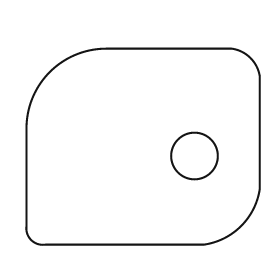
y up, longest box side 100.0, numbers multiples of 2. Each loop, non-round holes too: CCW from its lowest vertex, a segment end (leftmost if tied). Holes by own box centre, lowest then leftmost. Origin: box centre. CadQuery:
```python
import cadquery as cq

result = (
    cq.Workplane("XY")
    .moveTo(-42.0, -42.0)
    .lineTo(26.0, -42.0)
    .threePointArc((42.0, -34.0), (50.0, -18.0))
    .lineTo(50.0, 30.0)
    .threePointArc((46.0, 38.0), (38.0, 42.0))
    .lineTo(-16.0, 42.0)
    .threePointArc((-40.0, 32.0), (-50.0, 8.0))
    .lineTo(-50.0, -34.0)
    .threePointArc((-48.0, -40.0), (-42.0, -42.0))
    .close()
    .moveTo(22.0, -4.0)
    .circle(10.0)
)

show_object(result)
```